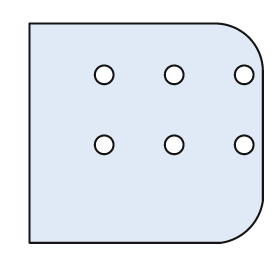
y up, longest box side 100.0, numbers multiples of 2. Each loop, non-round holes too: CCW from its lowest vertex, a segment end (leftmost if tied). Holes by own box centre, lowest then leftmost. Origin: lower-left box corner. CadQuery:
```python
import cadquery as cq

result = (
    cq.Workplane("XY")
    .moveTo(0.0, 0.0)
    .lineTo(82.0, 0.0)
    .threePointArc((94.0, 6.0), (100.0, 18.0))
    .lineTo(100.0, 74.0)
    .threePointArc((94.0, 88.0), (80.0, 94.0))
    .lineTo(0.0, 94.0)
    .close()
    .moveTo(32.0, 42.0)
    .circle(4.0)
    .moveTo(62.0, 42.0)
    .circle(4.0)
    .moveTo(92.0, 42.0)
    .circle(4.0)
    .moveTo(32.0, 72.0)
    .circle(4.0)
    .moveTo(62.0, 72.0)
    .circle(4.0)
    .moveTo(92.0, 72.0)
    .circle(4.0)
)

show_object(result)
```